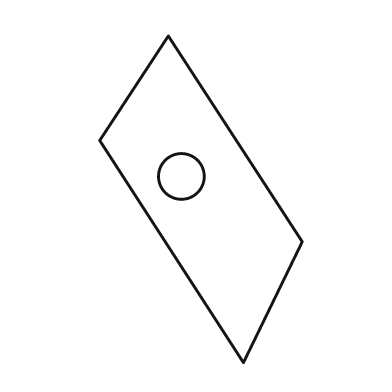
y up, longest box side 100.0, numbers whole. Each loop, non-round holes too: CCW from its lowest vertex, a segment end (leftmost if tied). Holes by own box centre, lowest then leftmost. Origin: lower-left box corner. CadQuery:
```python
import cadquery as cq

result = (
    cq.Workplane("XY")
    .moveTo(44.0, 0.0)
    .lineTo(62.0, 37.0)
    .lineTo(21.0, 100.0)
    .lineTo(0.0, 68.0)
    .close()
    .moveTo(25.0, 57.0)
    .circle(7.0)
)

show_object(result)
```